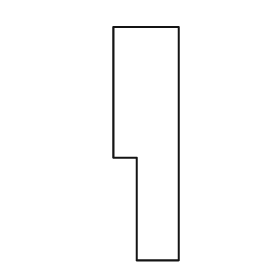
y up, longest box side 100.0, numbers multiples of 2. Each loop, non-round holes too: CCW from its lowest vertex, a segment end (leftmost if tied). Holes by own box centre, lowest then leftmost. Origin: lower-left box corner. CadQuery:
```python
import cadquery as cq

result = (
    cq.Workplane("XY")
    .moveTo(10.0, 0.0)
    .lineTo(28.0, 0.0)
    .lineTo(28.0, 100.0)
    .lineTo(0.0, 100.0)
    .lineTo(0.0, 44.0)
    .lineTo(10.0, 44.0)
    .close()
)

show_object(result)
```